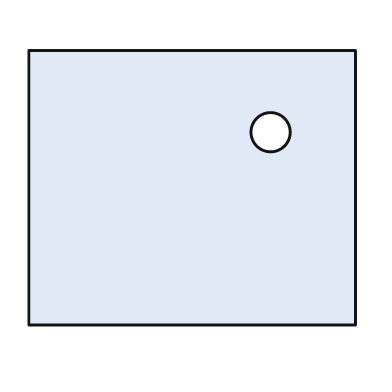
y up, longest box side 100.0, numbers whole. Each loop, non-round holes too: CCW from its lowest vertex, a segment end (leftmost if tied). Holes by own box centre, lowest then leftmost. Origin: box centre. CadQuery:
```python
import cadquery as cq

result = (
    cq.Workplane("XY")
    .moveTo(-50.0, -42.0)
    .lineTo(50.0, -42.0)
    .lineTo(50.0, 42.0)
    .lineTo(-50.0, 42.0)
    .close()
    .moveTo(24.0, 17.0)
    .circle(6.0)
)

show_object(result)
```